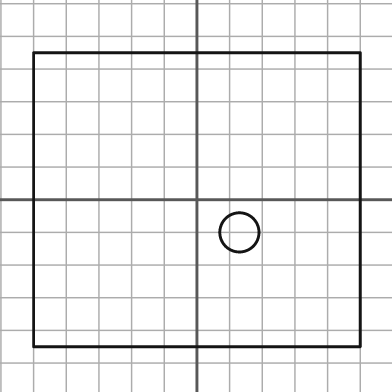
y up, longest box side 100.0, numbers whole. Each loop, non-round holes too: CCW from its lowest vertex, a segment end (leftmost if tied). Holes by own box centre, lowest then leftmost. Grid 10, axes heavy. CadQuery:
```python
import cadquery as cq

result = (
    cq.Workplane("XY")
    .moveTo(-50.0, -45.0)
    .lineTo(50.0, -45.0)
    .lineTo(50.0, 45.0)
    .lineTo(-50.0, 45.0)
    .close()
    .moveTo(13.0, -10.0)
    .circle(6.0)
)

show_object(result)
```